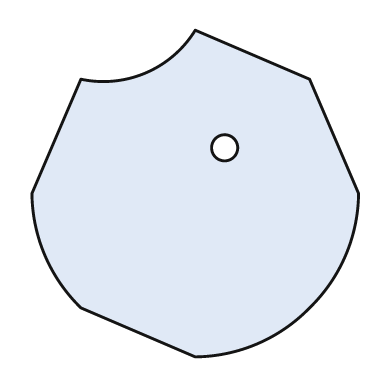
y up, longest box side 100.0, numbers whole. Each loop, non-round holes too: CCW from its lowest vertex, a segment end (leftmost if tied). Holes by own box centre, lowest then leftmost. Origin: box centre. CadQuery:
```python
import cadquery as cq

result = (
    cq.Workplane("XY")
    .moveTo(0.0, -50.0)
    .threePointArc((19.0, -46.0), (35.0, -35.0))
    .threePointArc((46.0, -19.0), (50.0, 0.0))
    .lineTo(35.0, 35.0)
    .lineTo(0.0, 50.0)
    .threePointArc((-15.0, 37.0), (-35.0, 35.0))
    .lineTo(-50.0, 0.0)
    .threePointArc((-46.0, -19.0), (-35.0, -35.0))
    .close()
    .moveTo(9.0, 14.0)
    .circle(4.0)
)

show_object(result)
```